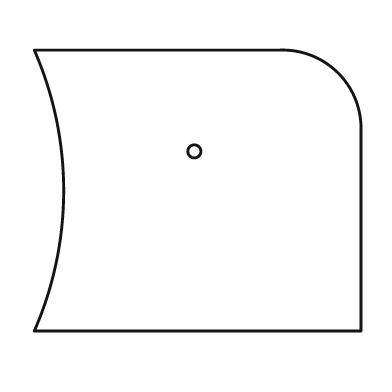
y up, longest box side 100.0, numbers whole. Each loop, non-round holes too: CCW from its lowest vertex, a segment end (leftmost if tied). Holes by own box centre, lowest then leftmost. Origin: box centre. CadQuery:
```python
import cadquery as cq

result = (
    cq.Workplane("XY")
    .moveTo(-50.0, -43.0)
    .lineTo(50.0, -43.0)
    .lineTo(50.0, 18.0)
    .threePointArc((43.0, 36.0), (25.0, 43.0))
    .lineTo(-50.0, 43.0)
    .threePointArc((-41.0, 0.0), (-50.0, -43.0))
    .close()
    .moveTo(-1.0, 12.0)
    .circle(2.0)
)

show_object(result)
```